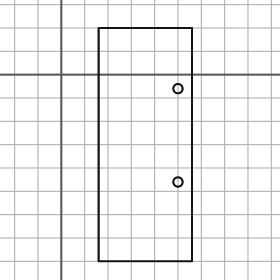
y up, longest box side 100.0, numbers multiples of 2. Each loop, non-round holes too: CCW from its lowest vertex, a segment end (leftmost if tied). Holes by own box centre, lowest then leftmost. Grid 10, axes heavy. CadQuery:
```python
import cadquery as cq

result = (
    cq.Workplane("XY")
    .moveTo(16.0, -80.0)
    .lineTo(56.0, -80.0)
    .lineTo(56.0, 20.0)
    .lineTo(16.0, 20.0)
    .close()
    .moveTo(50.0, -46.0)
    .circle(2.0)
    .moveTo(50.0, -6.0)
    .circle(2.0)
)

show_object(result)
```